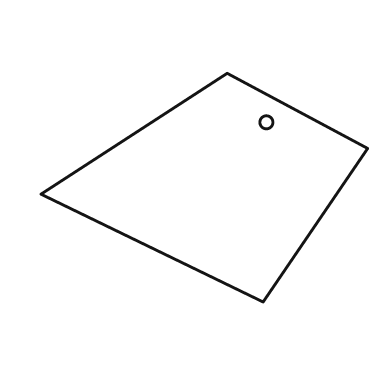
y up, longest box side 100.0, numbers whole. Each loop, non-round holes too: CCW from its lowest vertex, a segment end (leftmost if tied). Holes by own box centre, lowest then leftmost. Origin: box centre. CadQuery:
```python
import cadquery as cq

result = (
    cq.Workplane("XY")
    .moveTo(18.0, -35.0)
    .lineTo(50.0, 12.0)
    .lineTo(7.0, 35.0)
    .lineTo(-50.0, -2.0)
    .close()
    .moveTo(19.0, 20.0)
    .circle(2.0)
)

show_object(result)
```